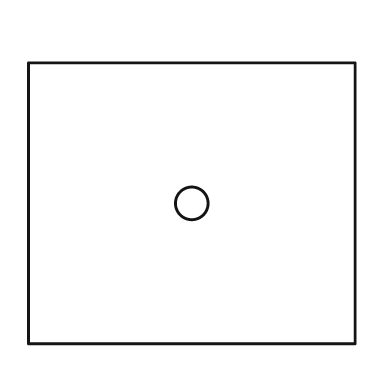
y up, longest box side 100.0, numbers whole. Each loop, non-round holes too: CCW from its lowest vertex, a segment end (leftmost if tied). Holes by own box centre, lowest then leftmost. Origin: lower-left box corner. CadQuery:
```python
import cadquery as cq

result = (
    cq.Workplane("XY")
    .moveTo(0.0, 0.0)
    .lineTo(100.0, 0.0)
    .lineTo(100.0, 86.0)
    .lineTo(0.0, 86.0)
    .close()
    .moveTo(50.0, 43.0)
    .circle(5.0)
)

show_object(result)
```